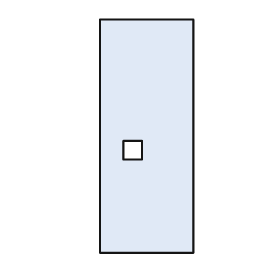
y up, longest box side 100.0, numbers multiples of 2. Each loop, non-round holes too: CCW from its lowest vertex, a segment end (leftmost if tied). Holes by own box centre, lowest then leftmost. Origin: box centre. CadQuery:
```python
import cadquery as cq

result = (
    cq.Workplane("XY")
    .moveTo(-20.0, -50.0)
    .lineTo(20.0, -50.0)
    .lineTo(20.0, 50.0)
    .lineTo(-20.0, 50.0)
    .close()
    .moveTo(-10.0, -10.0)
    .lineTo(-2.0, -10.0)
    .lineTo(-2.0, -2.0)
    .lineTo(-10.0, -2.0)
    .close()
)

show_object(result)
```